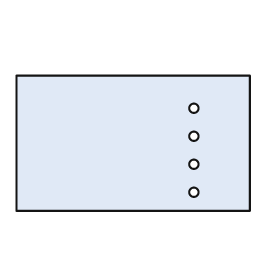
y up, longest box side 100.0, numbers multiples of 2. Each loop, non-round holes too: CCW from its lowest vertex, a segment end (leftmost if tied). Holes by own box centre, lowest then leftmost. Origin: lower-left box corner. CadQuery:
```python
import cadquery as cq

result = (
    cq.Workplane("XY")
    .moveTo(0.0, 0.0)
    .lineTo(100.0, 0.0)
    .lineTo(100.0, 58.0)
    .lineTo(0.0, 58.0)
    .close()
    .moveTo(76.0, 8.0)
    .circle(2.0)
    .moveTo(76.0, 20.0)
    .circle(2.0)
    .moveTo(76.0, 32.0)
    .circle(2.0)
    .moveTo(76.0, 44.0)
    .circle(2.0)
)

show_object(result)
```